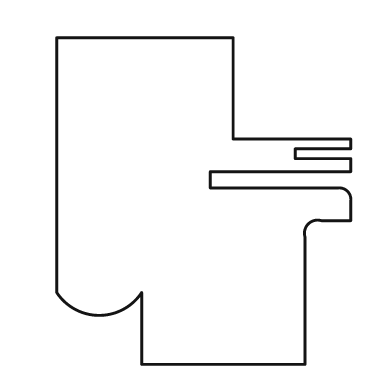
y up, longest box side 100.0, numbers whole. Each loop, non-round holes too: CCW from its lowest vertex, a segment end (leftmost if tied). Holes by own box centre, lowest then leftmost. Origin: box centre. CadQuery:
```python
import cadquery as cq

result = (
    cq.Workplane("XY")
    .moveTo(-19.0, -50.0)
    .lineTo(31.0, -50.0)
    .lineTo(31.0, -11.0)
    .threePointArc((32.0, -7.0), (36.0, -6.0))
    .lineTo(45.0, -6.0)
    .lineTo(45.0, 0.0)
    .threePointArc((44.0, 3.0), (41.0, 4.0))
    .lineTo(2.0, 4.0)
    .lineTo(2.0, 9.0)
    .lineTo(45.0, 9.0)
    .lineTo(45.0, 13.0)
    .lineTo(28.0, 13.0)
    .lineTo(28.0, 16.0)
    .lineTo(45.0, 16.0)
    .lineTo(45.0, 19.0)
    .lineTo(9.0, 19.0)
    .lineTo(9.0, 50.0)
    .lineTo(-45.0, 50.0)
    .lineTo(-45.0, -28.0)
    .threePointArc((-32.0, -35.0), (-19.0, -28.0))
    .close()
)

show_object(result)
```